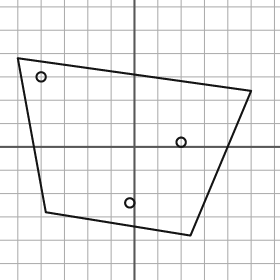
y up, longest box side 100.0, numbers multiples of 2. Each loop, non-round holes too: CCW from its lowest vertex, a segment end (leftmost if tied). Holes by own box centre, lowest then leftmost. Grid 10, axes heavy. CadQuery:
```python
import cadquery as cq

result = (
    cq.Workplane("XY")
    .moveTo(24.0, -38.0)
    .lineTo(50.0, 24.0)
    .lineTo(-50.0, 38.0)
    .lineTo(-38.0, -28.0)
    .close()
    .moveTo(-2.0, -24.0)
    .circle(2.0)
    .moveTo(20.0, 2.0)
    .circle(2.0)
    .moveTo(-40.0, 30.0)
    .circle(2.0)
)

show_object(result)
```